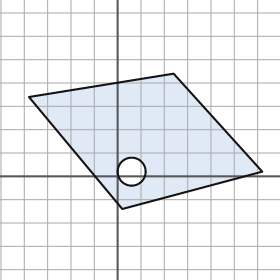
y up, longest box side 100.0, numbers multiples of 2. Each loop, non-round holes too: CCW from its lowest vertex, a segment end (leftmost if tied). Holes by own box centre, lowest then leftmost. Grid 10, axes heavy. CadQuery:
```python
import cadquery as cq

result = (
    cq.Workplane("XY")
    .moveTo(2.0, -14.0)
    .lineTo(62.0, 2.0)
    .lineTo(24.0, 44.0)
    .lineTo(-38.0, 34.0)
    .close()
    .moveTo(6.0, 2.0)
    .circle(6.0)
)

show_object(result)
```